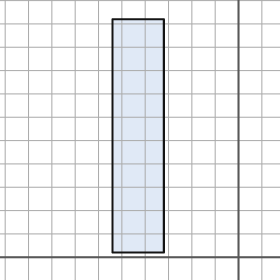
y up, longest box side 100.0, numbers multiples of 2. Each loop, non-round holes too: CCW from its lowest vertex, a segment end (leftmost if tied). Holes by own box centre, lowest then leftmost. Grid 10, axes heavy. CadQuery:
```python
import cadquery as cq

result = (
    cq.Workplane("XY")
    .moveTo(-54.0, 2.0)
    .lineTo(-32.0, 2.0)
    .lineTo(-32.0, 102.0)
    .lineTo(-54.0, 102.0)
    .close()
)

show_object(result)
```